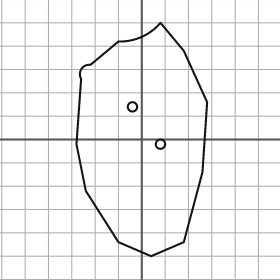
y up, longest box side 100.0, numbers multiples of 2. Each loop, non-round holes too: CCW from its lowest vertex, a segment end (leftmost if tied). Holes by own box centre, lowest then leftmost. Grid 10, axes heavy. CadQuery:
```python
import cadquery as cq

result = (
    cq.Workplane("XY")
    .moveTo(4.0, -50.0)
    .lineTo(18.0, -44.0)
    .lineTo(26.0, -14.0)
    .lineTo(28.0, 16.0)
    .lineTo(18.0, 38.0)
    .lineTo(8.0, 50.0)
    .threePointArc((0.0, 44.0), (-10.0, 42.0))
    .lineTo(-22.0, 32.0)
    .threePointArc((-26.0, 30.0), (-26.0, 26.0))
    .lineTo(-28.0, -2.0)
    .lineTo(-24.0, -22.0)
    .lineTo(-10.0, -44.0)
    .close()
    .moveTo(8.0, -2.0)
    .circle(2.0)
    .moveTo(-4.0, 14.0)
    .circle(2.0)
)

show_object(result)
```